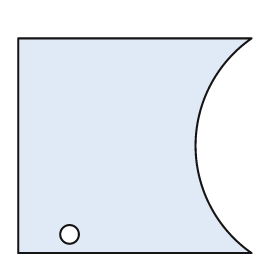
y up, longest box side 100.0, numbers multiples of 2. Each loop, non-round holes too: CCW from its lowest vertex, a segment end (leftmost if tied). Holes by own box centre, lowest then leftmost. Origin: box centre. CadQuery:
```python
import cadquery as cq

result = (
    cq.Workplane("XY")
    .moveTo(-50.0, -46.0)
    .lineTo(50.0, -46.0)
    .threePointArc((26.0, 0.0), (50.0, 46.0))
    .lineTo(-50.0, 46.0)
    .close()
    .moveTo(-28.0, -38.0)
    .circle(4.0)
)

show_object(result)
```